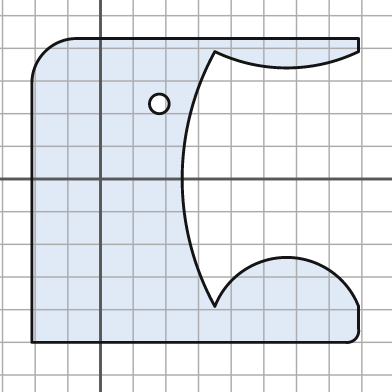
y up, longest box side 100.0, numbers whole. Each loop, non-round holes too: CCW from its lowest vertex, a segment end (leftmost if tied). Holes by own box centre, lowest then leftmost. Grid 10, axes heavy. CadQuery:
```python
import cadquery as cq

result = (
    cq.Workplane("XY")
    .moveTo(-21.0, -50.0)
    .lineTo(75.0, -50.0)
    .threePointArc((78.0, -49.0), (79.0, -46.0))
    .lineTo(79.0, -39.0)
    .threePointArc((57.0, -24.0), (35.0, -39.0))
    .threePointArc((25.0, 0.0), (35.0, 39.0))
    .threePointArc((57.0, 34.0), (79.0, 39.0))
    .lineTo(79.0, 43.0)
    .lineTo(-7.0, 43.0)
    .threePointArc((-17.0, 39.0), (-21.0, 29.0))
    .close()
    .moveTo(18.0, 23.0)
    .circle(3.0)
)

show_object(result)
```